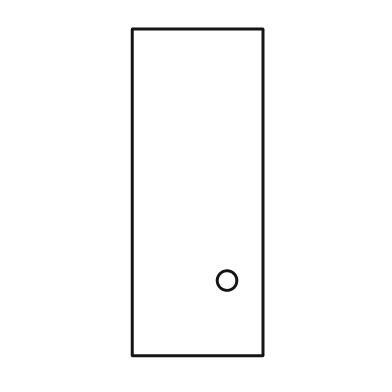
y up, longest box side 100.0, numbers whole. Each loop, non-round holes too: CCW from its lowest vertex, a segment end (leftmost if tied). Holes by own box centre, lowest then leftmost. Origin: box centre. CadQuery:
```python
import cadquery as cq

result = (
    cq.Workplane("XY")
    .moveTo(-20.0, -50.0)
    .lineTo(20.0, -50.0)
    .lineTo(20.0, 50.0)
    .lineTo(-20.0, 50.0)
    .close()
    .moveTo(9.0, -27.0)
    .circle(3.0)
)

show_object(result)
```